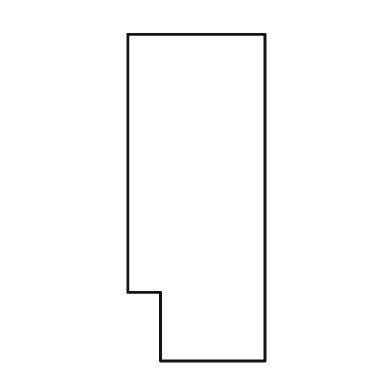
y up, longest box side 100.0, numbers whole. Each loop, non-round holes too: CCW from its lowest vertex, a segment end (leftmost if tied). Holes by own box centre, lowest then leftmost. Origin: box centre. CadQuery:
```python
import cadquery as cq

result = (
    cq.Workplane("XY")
    .moveTo(-11.0, -50.0)
    .lineTo(21.0, -50.0)
    .lineTo(21.0, 50.0)
    .lineTo(-21.0, 50.0)
    .lineTo(-21.0, -29.0)
    .lineTo(-11.0, -29.0)
    .close()
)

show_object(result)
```